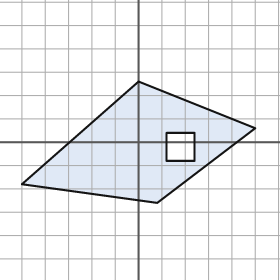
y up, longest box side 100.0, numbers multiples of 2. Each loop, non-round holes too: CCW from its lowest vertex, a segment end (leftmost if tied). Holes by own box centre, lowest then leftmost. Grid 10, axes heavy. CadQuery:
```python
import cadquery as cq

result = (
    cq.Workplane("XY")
    .moveTo(8.0, -26.0)
    .lineTo(50.0, 6.0)
    .lineTo(0.0, 26.0)
    .lineTo(-50.0, -18.0)
    .close()
    .moveTo(12.0, -8.0)
    .lineTo(24.0, -8.0)
    .lineTo(24.0, 4.0)
    .lineTo(12.0, 4.0)
    .close()
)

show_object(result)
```